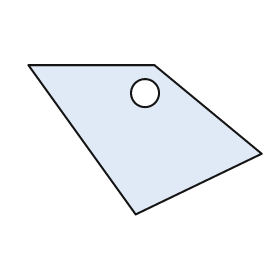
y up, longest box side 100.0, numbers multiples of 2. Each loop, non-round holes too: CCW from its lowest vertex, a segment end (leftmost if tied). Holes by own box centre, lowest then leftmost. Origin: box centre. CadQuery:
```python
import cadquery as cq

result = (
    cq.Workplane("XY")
    .moveTo(-4.0, -32.0)
    .lineTo(50.0, -6.0)
    .lineTo(4.0, 32.0)
    .lineTo(-50.0, 32.0)
    .close()
    .moveTo(0.0, 20.0)
    .circle(6.0)
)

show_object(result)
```